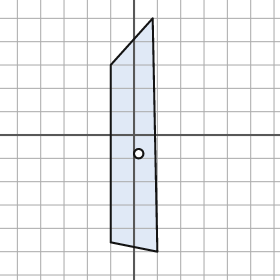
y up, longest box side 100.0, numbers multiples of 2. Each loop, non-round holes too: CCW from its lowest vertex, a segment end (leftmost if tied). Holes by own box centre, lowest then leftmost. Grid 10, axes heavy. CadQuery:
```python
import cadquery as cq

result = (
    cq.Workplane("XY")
    .moveTo(10.0, -50.0)
    .lineTo(8.0, 50.0)
    .lineTo(-10.0, 30.0)
    .lineTo(-10.0, -46.0)
    .close()
    .moveTo(2.0, -8.0)
    .circle(2.0)
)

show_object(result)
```